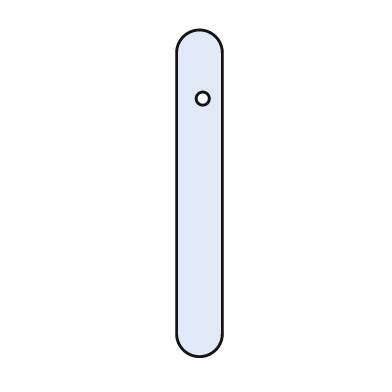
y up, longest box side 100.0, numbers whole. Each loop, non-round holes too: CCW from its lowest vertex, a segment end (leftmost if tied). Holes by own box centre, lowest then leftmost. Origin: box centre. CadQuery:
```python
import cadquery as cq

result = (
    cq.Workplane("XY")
    .moveTo(-7.0, -43.0)
    .threePointArc((0.0, -50.0), (7.0, -43.0))
    .lineTo(7.0, 43.0)
    .threePointArc((0.0, 50.0), (-7.0, 43.0))
    .close()
    .moveTo(1.0, 29.0)
    .circle(2.0)
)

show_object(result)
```